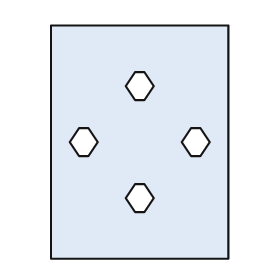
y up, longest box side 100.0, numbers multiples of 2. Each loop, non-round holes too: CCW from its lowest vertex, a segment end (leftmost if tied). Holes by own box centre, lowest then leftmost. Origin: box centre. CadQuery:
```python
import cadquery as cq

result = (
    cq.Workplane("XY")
    .moveTo(-38.0, -50.0)
    .lineTo(38.0, -50.0)
    .lineTo(38.0, 50.0)
    .lineTo(-38.0, 50.0)
    .close()
    .moveTo(-2.0, -30.0)
    .lineTo(2.0, -30.0)
    .lineTo(6.0, -24.0)
    .lineTo(2.0, -18.0)
    .lineTo(-2.0, -18.0)
    .lineTo(-6.0, -24.0)
    .close()
    .moveTo(-26.0, -6.0)
    .lineTo(-22.0, -6.0)
    .lineTo(-18.0, 0.0)
    .lineTo(-22.0, 6.0)
    .lineTo(-26.0, 6.0)
    .lineTo(-30.0, 0.0)
    .close()
    .moveTo(22.0, -6.0)
    .lineTo(26.0, -6.0)
    .lineTo(30.0, 0.0)
    .lineTo(26.0, 6.0)
    .lineTo(22.0, 6.0)
    .lineTo(18.0, 0.0)
    .close()
    .moveTo(-2.0, 18.0)
    .lineTo(2.0, 18.0)
    .lineTo(6.0, 24.0)
    .lineTo(2.0, 30.0)
    .lineTo(-2.0, 30.0)
    .lineTo(-6.0, 24.0)
    .close()
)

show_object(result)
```